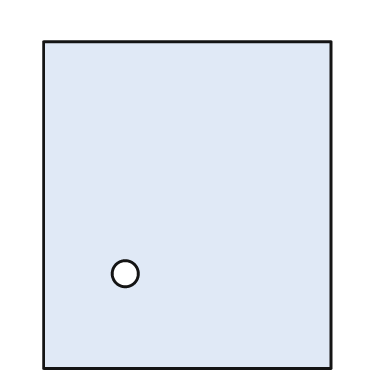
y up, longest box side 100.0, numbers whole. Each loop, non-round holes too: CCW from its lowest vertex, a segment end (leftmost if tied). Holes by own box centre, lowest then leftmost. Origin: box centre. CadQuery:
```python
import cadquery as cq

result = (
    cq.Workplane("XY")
    .moveTo(-44.0, -50.0)
    .lineTo(44.0, -50.0)
    .lineTo(44.0, 50.0)
    .lineTo(-44.0, 50.0)
    .close()
    .moveTo(-19.0, -21.0)
    .circle(4.0)
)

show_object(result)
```